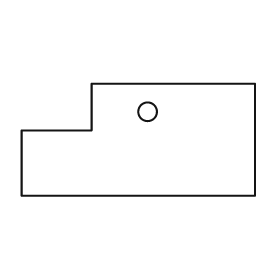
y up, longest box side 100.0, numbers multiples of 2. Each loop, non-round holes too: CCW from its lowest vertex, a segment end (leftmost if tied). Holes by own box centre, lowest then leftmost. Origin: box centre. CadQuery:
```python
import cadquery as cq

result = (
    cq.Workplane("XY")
    .moveTo(-50.0, -24.0)
    .lineTo(50.0, -24.0)
    .lineTo(50.0, 24.0)
    .lineTo(-20.0, 24.0)
    .lineTo(-20.0, 4.0)
    .lineTo(-50.0, 4.0)
    .close()
    .moveTo(4.0, 12.0)
    .circle(4.0)
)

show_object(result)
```